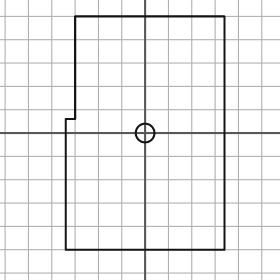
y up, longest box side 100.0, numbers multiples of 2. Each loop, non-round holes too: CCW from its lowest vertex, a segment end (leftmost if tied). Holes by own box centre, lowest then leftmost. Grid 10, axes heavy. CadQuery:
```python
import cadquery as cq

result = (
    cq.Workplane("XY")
    .moveTo(-34.0, -50.0)
    .lineTo(34.0, -50.0)
    .lineTo(34.0, 50.0)
    .lineTo(-30.0, 50.0)
    .lineTo(-30.0, 6.0)
    .lineTo(-34.0, 6.0)
    .close()
    .moveTo(0.0, 0.0)
    .circle(4.0)
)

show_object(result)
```